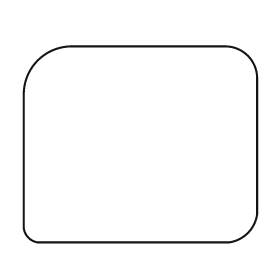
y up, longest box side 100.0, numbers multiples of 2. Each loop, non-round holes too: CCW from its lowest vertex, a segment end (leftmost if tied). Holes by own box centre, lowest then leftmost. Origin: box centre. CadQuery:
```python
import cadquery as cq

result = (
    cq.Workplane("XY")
    .moveTo(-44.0, -42.0)
    .lineTo(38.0, -42.0)
    .threePointArc((46.0, -38.0), (50.0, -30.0))
    .lineTo(50.0, 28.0)
    .threePointArc((46.0, 38.0), (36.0, 42.0))
    .lineTo(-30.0, 42.0)
    .threePointArc((-44.0, 36.0), (-50.0, 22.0))
    .lineTo(-50.0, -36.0)
    .threePointArc((-48.0, -40.0), (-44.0, -42.0))
    .close()
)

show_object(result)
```